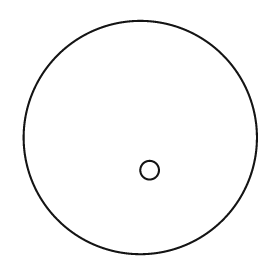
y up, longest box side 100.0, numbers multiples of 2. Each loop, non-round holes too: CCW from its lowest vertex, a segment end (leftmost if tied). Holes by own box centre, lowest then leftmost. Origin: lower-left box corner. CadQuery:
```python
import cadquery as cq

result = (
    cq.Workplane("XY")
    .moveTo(50.0, 50.0)
    .circle(50.0)
    .moveTo(54.0, 36.0)
    .circle(4.0)
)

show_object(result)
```